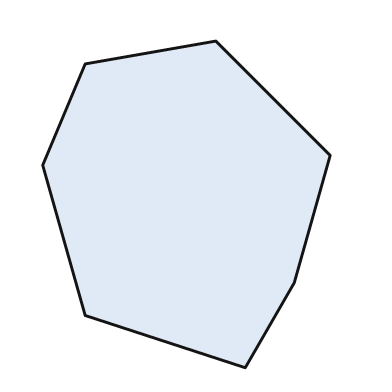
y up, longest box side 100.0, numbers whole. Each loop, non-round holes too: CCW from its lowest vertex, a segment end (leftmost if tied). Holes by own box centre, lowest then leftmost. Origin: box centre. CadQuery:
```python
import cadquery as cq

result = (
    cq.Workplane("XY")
    .moveTo(18.0, -50.0)
    .lineTo(33.0, -24.0)
    .lineTo(44.0, 15.0)
    .lineTo(9.0, 50.0)
    .lineTo(-31.0, 43.0)
    .lineTo(-44.0, 12.0)
    .lineTo(-31.0, -34.0)
    .close()
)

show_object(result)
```